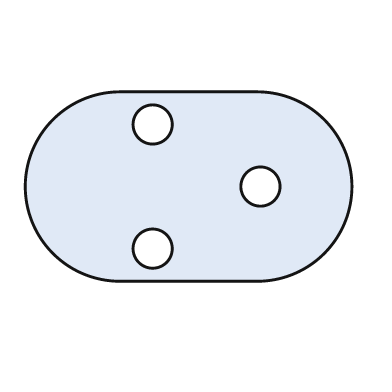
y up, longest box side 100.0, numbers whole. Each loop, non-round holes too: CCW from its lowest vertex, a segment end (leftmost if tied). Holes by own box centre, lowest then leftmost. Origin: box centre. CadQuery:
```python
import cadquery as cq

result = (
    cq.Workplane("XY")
    .moveTo(-21.0, -29.0)
    .lineTo(21.0, -29.0)
    .threePointArc((50.0, 0.0), (21.0, 29.0))
    .lineTo(-21.0, 29.0)
    .threePointArc((-50.0, 0.0), (-21.0, -29.0))
    .close()
    .moveTo(-11.0, -19.0)
    .circle(6.0)
    .moveTo(22.0, 0.0)
    .circle(6.0)
    .moveTo(-11.0, 19.0)
    .circle(6.0)
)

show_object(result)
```